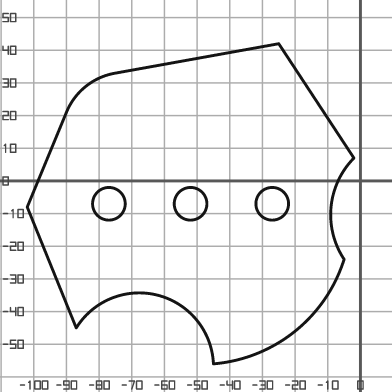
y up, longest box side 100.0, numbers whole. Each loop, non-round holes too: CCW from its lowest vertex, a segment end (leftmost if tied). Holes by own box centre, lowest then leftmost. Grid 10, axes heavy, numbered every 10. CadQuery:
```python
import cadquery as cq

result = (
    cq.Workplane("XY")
    .moveTo(-45.0, -56.0)
    .threePointArc((-20.0, -46.0), (-5.0, -24.0))
    .threePointArc((-9.0, -8.0), (-2.0, 7.0))
    .lineTo(-25.0, 42.0)
    .lineTo(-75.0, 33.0)
    .threePointArc((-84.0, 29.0), (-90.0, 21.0))
    .lineTo(-102.0, -8.0)
    .lineTo(-87.0, -45.0)
    .threePointArc((-62.0, -35.0), (-45.0, -56.0))
    .close()
    .moveTo(-77.0, -7.0)
    .circle(5.0)
    .moveTo(-52.0, -7.0)
    .circle(5.0)
    .moveTo(-27.0, -7.0)
    .circle(5.0)
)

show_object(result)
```